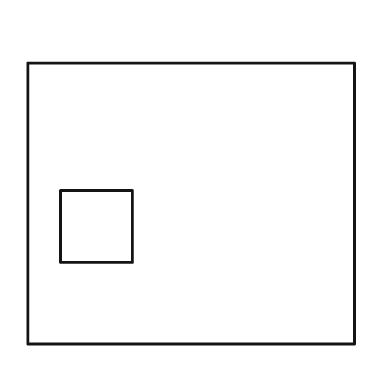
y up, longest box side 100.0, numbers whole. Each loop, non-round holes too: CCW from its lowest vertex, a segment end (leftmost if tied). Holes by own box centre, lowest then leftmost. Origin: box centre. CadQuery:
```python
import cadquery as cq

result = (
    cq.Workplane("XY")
    .moveTo(-50.0, -43.0)
    .lineTo(50.0, -43.0)
    .lineTo(50.0, 43.0)
    .lineTo(-50.0, 43.0)
    .close()
    .moveTo(-40.0, -18.0)
    .lineTo(-18.0, -18.0)
    .lineTo(-18.0, 4.0)
    .lineTo(-40.0, 4.0)
    .close()
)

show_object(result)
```